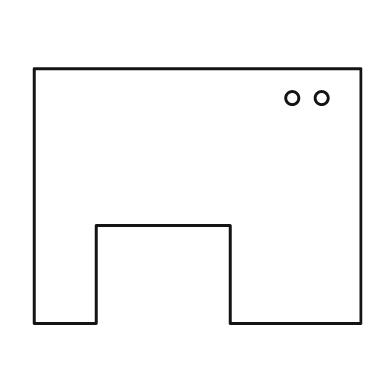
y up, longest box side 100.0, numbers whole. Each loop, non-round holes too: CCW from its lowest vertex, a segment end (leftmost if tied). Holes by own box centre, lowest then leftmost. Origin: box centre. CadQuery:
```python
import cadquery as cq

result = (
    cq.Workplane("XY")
    .moveTo(-50.0, -39.0)
    .lineTo(-31.0, -39.0)
    .lineTo(-31.0, -9.0)
    .lineTo(10.0, -9.0)
    .lineTo(10.0, -39.0)
    .lineTo(50.0, -39.0)
    .lineTo(50.0, 39.0)
    .lineTo(-50.0, 39.0)
    .close()
    .moveTo(29.0, 30.0)
    .circle(2.0)
    .moveTo(38.0, 30.0)
    .circle(2.0)
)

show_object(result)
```